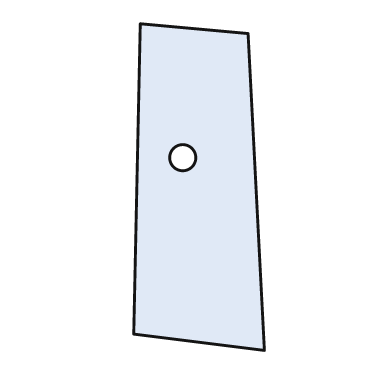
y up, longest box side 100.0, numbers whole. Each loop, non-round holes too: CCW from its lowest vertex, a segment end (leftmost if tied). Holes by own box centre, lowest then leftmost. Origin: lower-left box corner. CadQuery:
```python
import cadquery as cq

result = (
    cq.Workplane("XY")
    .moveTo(40.0, 0.0)
    .lineTo(35.0, 97.0)
    .lineTo(2.0, 100.0)
    .lineTo(0.0, 5.0)
    .close()
    .moveTo(15.0, 59.0)
    .circle(4.0)
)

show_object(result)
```